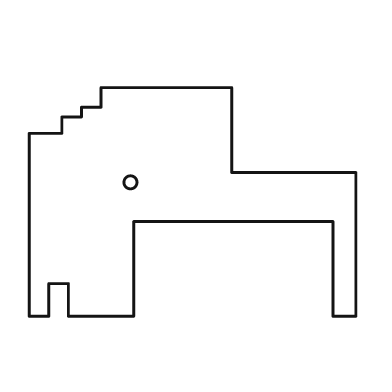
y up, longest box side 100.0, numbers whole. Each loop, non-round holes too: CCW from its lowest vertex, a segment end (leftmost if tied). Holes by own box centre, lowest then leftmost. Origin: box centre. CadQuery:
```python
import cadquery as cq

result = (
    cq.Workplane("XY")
    .moveTo(-50.0, -35.0)
    .lineTo(-44.0, -35.0)
    .lineTo(-44.0, -25.0)
    .lineTo(-38.0, -25.0)
    .lineTo(-38.0, -35.0)
    .lineTo(-18.0, -35.0)
    .lineTo(-18.0, -6.0)
    .lineTo(43.0, -6.0)
    .lineTo(43.0, -35.0)
    .lineTo(50.0, -35.0)
    .lineTo(50.0, 9.0)
    .lineTo(12.0, 9.0)
    .lineTo(12.0, 35.0)
    .lineTo(-28.0, 35.0)
    .lineTo(-28.0, 29.0)
    .lineTo(-34.0, 29.0)
    .lineTo(-34.0, 26.0)
    .lineTo(-40.0, 26.0)
    .lineTo(-40.0, 21.0)
    .lineTo(-50.0, 21.0)
    .close()
    .moveTo(-19.0, 6.0)
    .circle(2.0)
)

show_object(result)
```